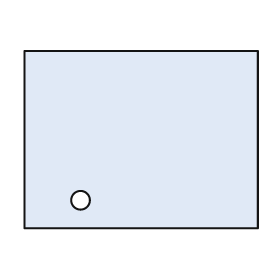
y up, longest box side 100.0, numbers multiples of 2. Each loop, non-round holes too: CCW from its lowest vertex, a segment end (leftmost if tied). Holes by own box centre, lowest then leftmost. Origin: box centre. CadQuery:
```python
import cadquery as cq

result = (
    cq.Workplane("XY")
    .moveTo(-50.0, -38.0)
    .lineTo(50.0, -38.0)
    .lineTo(50.0, 38.0)
    .lineTo(-50.0, 38.0)
    .close()
    .moveTo(-26.0, -26.0)
    .circle(4.0)
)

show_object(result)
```